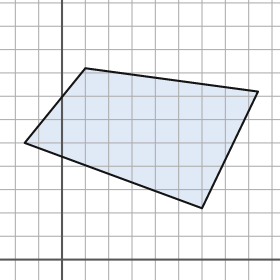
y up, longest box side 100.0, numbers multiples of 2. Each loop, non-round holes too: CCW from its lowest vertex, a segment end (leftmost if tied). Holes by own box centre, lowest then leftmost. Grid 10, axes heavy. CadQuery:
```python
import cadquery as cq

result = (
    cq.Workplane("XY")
    .moveTo(60.0, 22.0)
    .lineTo(84.0, 72.0)
    .lineTo(10.0, 82.0)
    .lineTo(-16.0, 50.0)
    .close()
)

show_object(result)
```